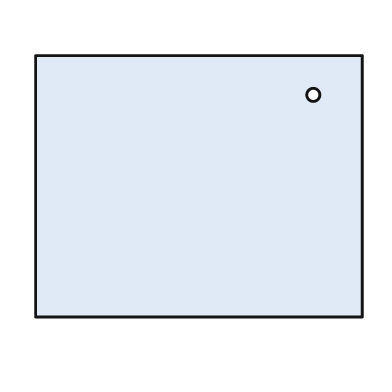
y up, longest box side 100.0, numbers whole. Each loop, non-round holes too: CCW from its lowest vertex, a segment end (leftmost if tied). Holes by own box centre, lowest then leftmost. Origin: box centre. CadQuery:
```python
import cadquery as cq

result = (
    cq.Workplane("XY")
    .moveTo(-50.0, -40.0)
    .lineTo(50.0, -40.0)
    .lineTo(50.0, 40.0)
    .lineTo(-50.0, 40.0)
    .close()
    .moveTo(35.0, 28.0)
    .circle(2.0)
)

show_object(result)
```